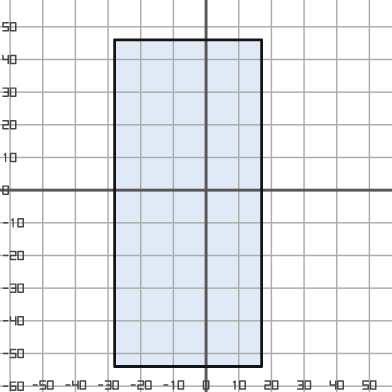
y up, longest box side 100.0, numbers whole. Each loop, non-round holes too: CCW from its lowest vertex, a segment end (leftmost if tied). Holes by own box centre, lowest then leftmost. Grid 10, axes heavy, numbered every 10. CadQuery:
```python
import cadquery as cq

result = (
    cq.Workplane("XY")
    .moveTo(-28.0, -54.0)
    .lineTo(17.0, -54.0)
    .lineTo(17.0, 46.0)
    .lineTo(-28.0, 46.0)
    .close()
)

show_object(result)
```